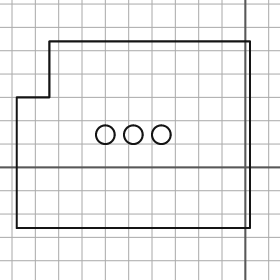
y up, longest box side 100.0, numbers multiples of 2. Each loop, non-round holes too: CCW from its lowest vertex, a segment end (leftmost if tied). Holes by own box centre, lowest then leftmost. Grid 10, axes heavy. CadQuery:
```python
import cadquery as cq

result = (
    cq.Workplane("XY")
    .moveTo(-98.0, -26.0)
    .lineTo(2.0, -26.0)
    .lineTo(2.0, 54.0)
    .lineTo(-84.0, 54.0)
    .lineTo(-84.0, 30.0)
    .lineTo(-98.0, 30.0)
    .close()
    .moveTo(-60.0, 14.0)
    .circle(4.0)
    .moveTo(-48.0, 14.0)
    .circle(4.0)
    .moveTo(-36.0, 14.0)
    .circle(4.0)
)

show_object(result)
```